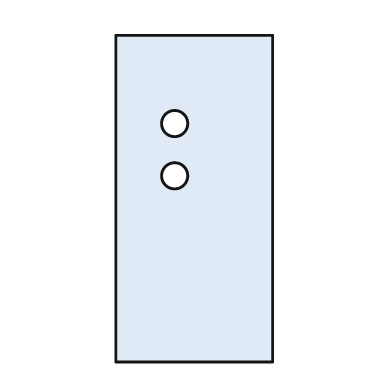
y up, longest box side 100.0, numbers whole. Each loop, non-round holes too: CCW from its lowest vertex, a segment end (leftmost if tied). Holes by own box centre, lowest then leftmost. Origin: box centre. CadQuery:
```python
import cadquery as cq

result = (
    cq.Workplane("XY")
    .moveTo(-24.0, -50.0)
    .lineTo(24.0, -50.0)
    .lineTo(24.0, 50.0)
    .lineTo(-24.0, 50.0)
    .close()
    .moveTo(-6.0, 7.0)
    .circle(4.0)
    .moveTo(-6.0, 23.0)
    .circle(4.0)
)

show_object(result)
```